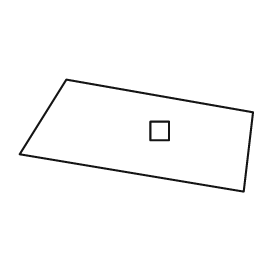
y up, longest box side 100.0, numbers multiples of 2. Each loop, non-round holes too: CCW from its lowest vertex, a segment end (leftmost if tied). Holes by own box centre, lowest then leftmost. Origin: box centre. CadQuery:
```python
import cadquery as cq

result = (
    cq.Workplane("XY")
    .moveTo(46.0, -24.0)
    .lineTo(50.0, 10.0)
    .lineTo(-30.0, 24.0)
    .lineTo(-50.0, -8.0)
    .close()
    .moveTo(6.0, -2.0)
    .lineTo(14.0, -2.0)
    .lineTo(14.0, 6.0)
    .lineTo(6.0, 6.0)
    .close()
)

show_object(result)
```